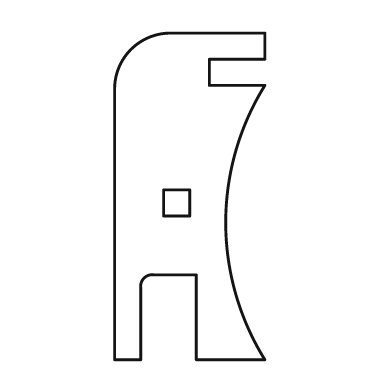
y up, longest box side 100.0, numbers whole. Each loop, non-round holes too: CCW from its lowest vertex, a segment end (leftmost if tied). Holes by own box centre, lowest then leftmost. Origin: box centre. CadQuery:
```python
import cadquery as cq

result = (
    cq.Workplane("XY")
    .moveTo(-23.0, -50.0)
    .lineTo(-15.0, -50.0)
    .lineTo(-15.0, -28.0)
    .threePointArc((-14.0, -25.0), (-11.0, -24.0))
    .lineTo(2.0, -24.0)
    .lineTo(2.0, -50.0)
    .lineTo(23.0, -50.0)
    .threePointArc((11.0, -8.0), (23.0, 34.0))
    .lineTo(6.0, 34.0)
    .lineTo(6.0, 42.0)
    .lineTo(23.0, 42.0)
    .lineTo(23.0, 50.0)
    .lineTo(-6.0, 50.0)
    .threePointArc((-18.0, 45.0), (-23.0, 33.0))
    .close()
    .moveTo(-8.0, -6.0)
    .lineTo(0.0, -6.0)
    .lineTo(0.0, 2.0)
    .lineTo(-8.0, 2.0)
    .close()
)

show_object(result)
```